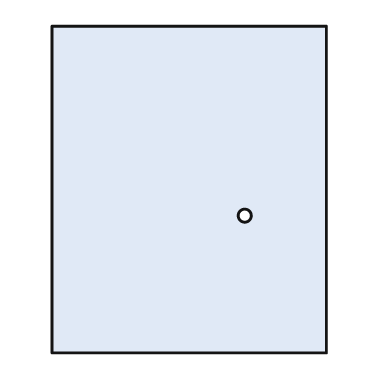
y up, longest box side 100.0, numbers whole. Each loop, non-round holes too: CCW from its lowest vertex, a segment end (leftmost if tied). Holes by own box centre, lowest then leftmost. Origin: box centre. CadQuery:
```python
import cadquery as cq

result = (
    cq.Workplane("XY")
    .moveTo(-42.0, -50.0)
    .lineTo(42.0, -50.0)
    .lineTo(42.0, 50.0)
    .lineTo(-42.0, 50.0)
    .close()
    .moveTo(17.0, -8.0)
    .circle(2.0)
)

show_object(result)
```